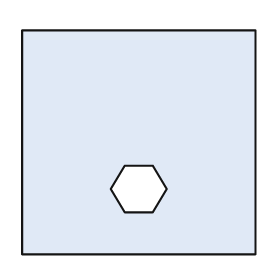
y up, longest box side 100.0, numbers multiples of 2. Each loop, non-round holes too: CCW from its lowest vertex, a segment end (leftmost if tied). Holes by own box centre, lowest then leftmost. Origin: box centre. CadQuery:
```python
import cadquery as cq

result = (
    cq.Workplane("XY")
    .moveTo(-50.0, -48.0)
    .lineTo(50.0, -48.0)
    .lineTo(50.0, 48.0)
    .lineTo(-50.0, 48.0)
    .close()
    .moveTo(-6.0, -30.0)
    .lineTo(6.0, -30.0)
    .lineTo(12.0, -20.0)
    .lineTo(6.0, -10.0)
    .lineTo(-6.0, -10.0)
    .lineTo(-12.0, -20.0)
    .close()
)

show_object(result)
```